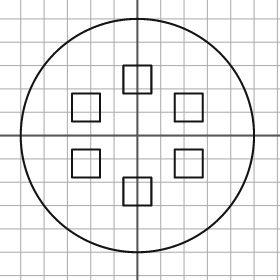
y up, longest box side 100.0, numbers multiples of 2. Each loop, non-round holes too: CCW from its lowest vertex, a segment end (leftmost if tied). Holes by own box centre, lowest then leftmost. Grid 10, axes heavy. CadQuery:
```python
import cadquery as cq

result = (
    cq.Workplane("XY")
    .moveTo(0.0, 0.0)
    .circle(50.0)
    .moveTo(-6.0, -30.0)
    .lineTo(6.0, -30.0)
    .lineTo(6.0, -18.0)
    .lineTo(-6.0, -18.0)
    .close()
    .moveTo(-28.0, -18.0)
    .lineTo(-16.0, -18.0)
    .lineTo(-16.0, -6.0)
    .lineTo(-28.0, -6.0)
    .close()
    .moveTo(16.0, -18.0)
    .lineTo(28.0, -18.0)
    .lineTo(28.0, -6.0)
    .lineTo(16.0, -6.0)
    .close()
    .moveTo(-28.0, 6.0)
    .lineTo(-16.0, 6.0)
    .lineTo(-16.0, 18.0)
    .lineTo(-28.0, 18.0)
    .close()
    .moveTo(16.0, 6.0)
    .lineTo(28.0, 6.0)
    .lineTo(28.0, 18.0)
    .lineTo(16.0, 18.0)
    .close()
    .moveTo(-6.0, 18.0)
    .lineTo(6.0, 18.0)
    .lineTo(6.0, 30.0)
    .lineTo(-6.0, 30.0)
    .close()
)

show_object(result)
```